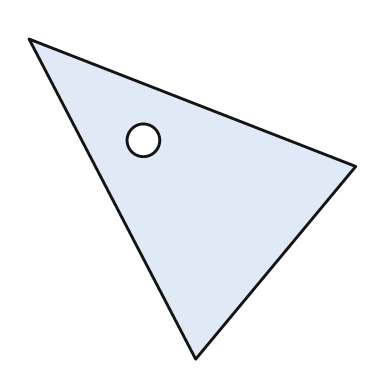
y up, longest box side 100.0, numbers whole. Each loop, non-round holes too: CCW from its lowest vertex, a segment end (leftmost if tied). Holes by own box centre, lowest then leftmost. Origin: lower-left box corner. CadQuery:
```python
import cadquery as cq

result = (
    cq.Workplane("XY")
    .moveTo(51.0, 0.0)
    .lineTo(100.0, 59.0)
    .lineTo(0.0, 98.0)
    .close()
    .moveTo(35.0, 67.0)
    .circle(5.0)
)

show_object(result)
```